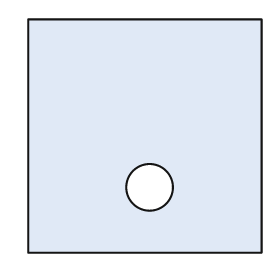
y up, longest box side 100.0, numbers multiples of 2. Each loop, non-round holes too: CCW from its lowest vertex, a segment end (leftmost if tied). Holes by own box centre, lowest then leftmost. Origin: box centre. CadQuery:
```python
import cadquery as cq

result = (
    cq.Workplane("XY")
    .moveTo(-50.0, -50.0)
    .lineTo(50.0, -50.0)
    .lineTo(50.0, 50.0)
    .lineTo(-50.0, 50.0)
    .close()
    .moveTo(2.0, -22.0)
    .circle(10.0)
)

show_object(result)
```